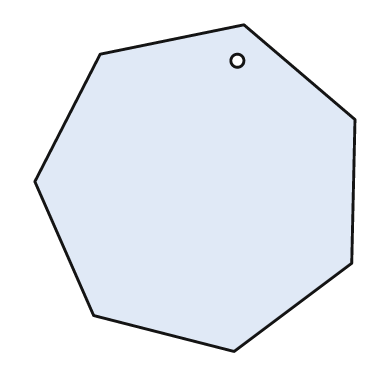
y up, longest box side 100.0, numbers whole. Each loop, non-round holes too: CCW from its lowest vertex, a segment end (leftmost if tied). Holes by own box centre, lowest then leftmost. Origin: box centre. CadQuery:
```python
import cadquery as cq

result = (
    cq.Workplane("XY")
    .moveTo(12.0, -50.0)
    .lineTo(48.0, -23.0)
    .lineTo(49.0, 21.0)
    .lineTo(15.0, 50.0)
    .lineTo(-29.0, 41.0)
    .lineTo(-49.0, 2.0)
    .lineTo(-31.0, -39.0)
    .close()
    .moveTo(13.0, 39.0)
    .circle(2.0)
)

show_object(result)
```